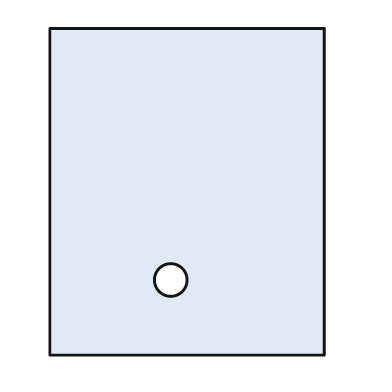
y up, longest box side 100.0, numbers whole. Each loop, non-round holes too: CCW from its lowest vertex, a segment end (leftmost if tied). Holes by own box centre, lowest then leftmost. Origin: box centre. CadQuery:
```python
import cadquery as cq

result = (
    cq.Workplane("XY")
    .moveTo(-42.0, -50.0)
    .lineTo(42.0, -50.0)
    .lineTo(42.0, 50.0)
    .lineTo(-42.0, 50.0)
    .close()
    .moveTo(-5.0, -27.0)
    .circle(5.0)
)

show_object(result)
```